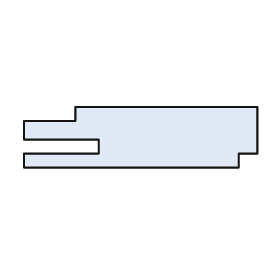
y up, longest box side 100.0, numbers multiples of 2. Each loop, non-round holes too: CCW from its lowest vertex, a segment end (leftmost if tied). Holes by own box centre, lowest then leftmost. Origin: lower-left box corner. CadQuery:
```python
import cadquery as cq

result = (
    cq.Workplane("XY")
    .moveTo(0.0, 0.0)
    .lineTo(92.0, 0.0)
    .lineTo(92.0, 6.0)
    .lineTo(100.0, 6.0)
    .lineTo(100.0, 26.0)
    .lineTo(22.0, 26.0)
    .lineTo(22.0, 20.0)
    .lineTo(0.0, 20.0)
    .lineTo(0.0, 12.0)
    .lineTo(32.0, 12.0)
    .lineTo(32.0, 6.0)
    .lineTo(0.0, 6.0)
    .close()
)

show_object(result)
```